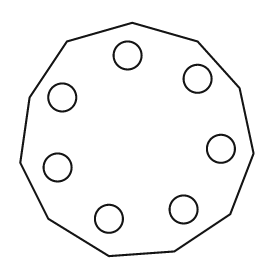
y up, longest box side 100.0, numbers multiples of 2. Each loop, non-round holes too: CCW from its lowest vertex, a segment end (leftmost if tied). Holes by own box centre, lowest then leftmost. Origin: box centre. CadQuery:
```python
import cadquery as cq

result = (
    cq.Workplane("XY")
    .moveTo(-12.0, -50.0)
    .lineTo(16.0, -48.0)
    .lineTo(40.0, -32.0)
    .lineTo(50.0, -6.0)
    .lineTo(44.0, 22.0)
    .lineTo(26.0, 42.0)
    .lineTo(-2.0, 50.0)
    .lineTo(-30.0, 42.0)
    .lineTo(-46.0, 18.0)
    .lineTo(-50.0, -10.0)
    .lineTo(-38.0, -34.0)
    .close()
    .moveTo(-12.0, -34.0)
    .circle(6.0)
    .moveTo(20.0, -30.0)
    .circle(6.0)
    .moveTo(-34.0, -12.0)
    .circle(6.0)
    .moveTo(36.0, -4.0)
    .circle(6.0)
    .moveTo(-32.0, 18.0)
    .circle(6.0)
    .moveTo(26.0, 26.0)
    .circle(6.0)
    .moveTo(-4.0, 36.0)
    .circle(6.0)
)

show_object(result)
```